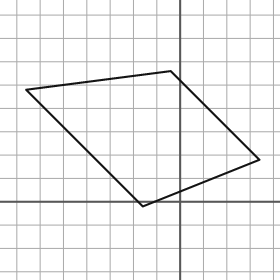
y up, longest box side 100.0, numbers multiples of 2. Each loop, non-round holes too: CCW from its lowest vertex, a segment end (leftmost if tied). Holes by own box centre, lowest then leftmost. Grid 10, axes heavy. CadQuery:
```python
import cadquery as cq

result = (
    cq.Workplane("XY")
    .moveTo(-16.0, -2.0)
    .lineTo(34.0, 18.0)
    .lineTo(-4.0, 56.0)
    .lineTo(-66.0, 48.0)
    .close()
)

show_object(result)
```